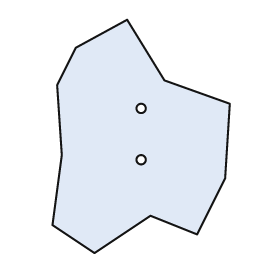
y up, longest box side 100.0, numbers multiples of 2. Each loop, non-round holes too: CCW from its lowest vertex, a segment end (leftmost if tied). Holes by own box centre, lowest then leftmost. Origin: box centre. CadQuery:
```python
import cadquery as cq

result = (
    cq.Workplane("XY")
    .moveTo(-20.0, -50.0)
    .lineTo(4.0, -34.0)
    .lineTo(24.0, -42.0)
    .lineTo(36.0, -18.0)
    .lineTo(38.0, 14.0)
    .lineTo(10.0, 24.0)
    .lineTo(-6.0, 50.0)
    .lineTo(-28.0, 38.0)
    .lineTo(-36.0, 22.0)
    .lineTo(-34.0, -8.0)
    .lineTo(-38.0, -38.0)
    .close()
    .moveTo(0.0, -10.0)
    .circle(2.0)
    .moveTo(0.0, 12.0)
    .circle(2.0)
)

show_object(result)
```